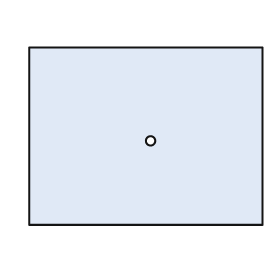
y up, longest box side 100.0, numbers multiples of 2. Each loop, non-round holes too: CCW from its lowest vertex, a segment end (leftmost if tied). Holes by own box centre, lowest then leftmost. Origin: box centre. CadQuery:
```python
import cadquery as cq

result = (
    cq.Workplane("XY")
    .moveTo(-50.0, -38.0)
    .lineTo(50.0, -38.0)
    .lineTo(50.0, 38.0)
    .lineTo(-50.0, 38.0)
    .close()
    .moveTo(2.0, -2.0)
    .circle(2.0)
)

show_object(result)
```